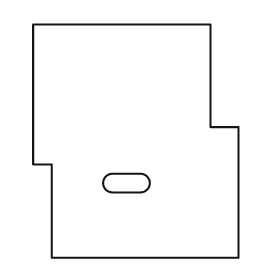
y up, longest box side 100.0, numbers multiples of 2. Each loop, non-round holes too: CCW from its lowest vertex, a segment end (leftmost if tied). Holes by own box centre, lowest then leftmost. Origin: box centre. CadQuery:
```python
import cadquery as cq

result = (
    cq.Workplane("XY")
    .moveTo(-36.0, -50.0)
    .lineTo(44.0, -50.0)
    .lineTo(44.0, 6.0)
    .lineTo(32.0, 6.0)
    .lineTo(32.0, 50.0)
    .lineTo(-44.0, 50.0)
    .lineTo(-44.0, -10.0)
    .lineTo(-36.0, -10.0)
    .close()
    .moveTo(-10.0, -22.0)
    .lineTo(2.0, -22.0)
    .threePointArc((6.0, -18.0), (2.0, -14.0))
    .lineTo(-10.0, -14.0)
    .threePointArc((-14.0, -18.0), (-10.0, -22.0))
    .close()
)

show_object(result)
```